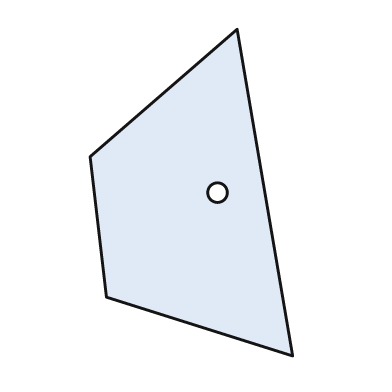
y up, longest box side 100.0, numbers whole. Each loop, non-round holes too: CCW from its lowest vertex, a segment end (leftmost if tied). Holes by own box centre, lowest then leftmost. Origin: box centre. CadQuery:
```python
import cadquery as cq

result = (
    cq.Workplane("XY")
    .moveTo(31.0, -50.0)
    .lineTo(14.0, 50.0)
    .lineTo(-31.0, 11.0)
    .lineTo(-26.0, -32.0)
    .close()
    .moveTo(8.0, 0.0)
    .circle(3.0)
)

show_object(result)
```